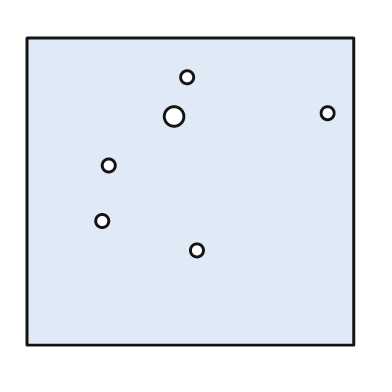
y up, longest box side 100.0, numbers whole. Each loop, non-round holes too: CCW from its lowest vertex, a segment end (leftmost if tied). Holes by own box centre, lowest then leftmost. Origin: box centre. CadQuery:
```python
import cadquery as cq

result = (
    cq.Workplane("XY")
    .moveTo(-50.0, -47.0)
    .lineTo(50.0, -47.0)
    .lineTo(50.0, 47.0)
    .lineTo(-50.0, 47.0)
    .close()
    .moveTo(2.0, -18.0)
    .circle(2.0)
    .moveTo(-27.0, -9.0)
    .circle(2.0)
    .moveTo(-25.0, 8.0)
    .circle(2.0)
    .moveTo(-5.0, 23.0)
    .circle(3.0)
    .moveTo(42.0, 24.0)
    .circle(2.0)
    .moveTo(-1.0, 35.0)
    .circle(2.0)
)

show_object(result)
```